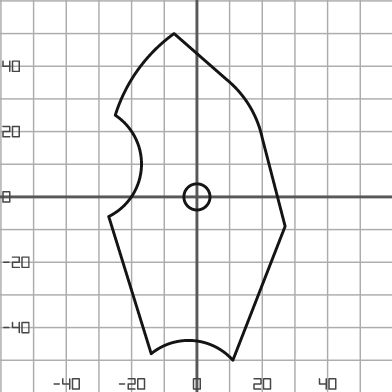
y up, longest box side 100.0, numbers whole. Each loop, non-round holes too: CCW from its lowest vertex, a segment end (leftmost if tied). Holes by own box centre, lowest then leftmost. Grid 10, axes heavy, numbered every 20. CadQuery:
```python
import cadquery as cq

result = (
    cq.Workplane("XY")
    .moveTo(11.0, -50.0)
    .lineTo(27.0, -9.0)
    .lineTo(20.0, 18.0)
    .threePointArc((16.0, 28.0), (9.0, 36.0))
    .lineTo(-7.0, 50.0)
    .threePointArc((-18.0, 39.0), (-25.0, 25.0))
    .threePointArc((-17.0, 9.0), (-27.0, -6.0))
    .lineTo(-14.0, -48.0)
    .threePointArc((-1.0, -44.0), (11.0, -50.0))
    .close()
    .moveTo(0.0, 0.0)
    .circle(4.0)
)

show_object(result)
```